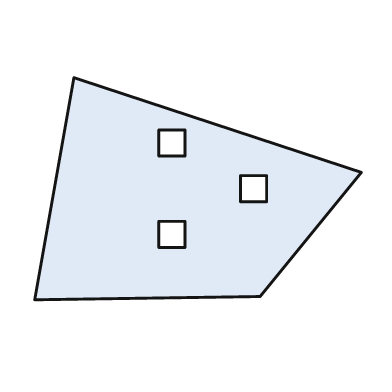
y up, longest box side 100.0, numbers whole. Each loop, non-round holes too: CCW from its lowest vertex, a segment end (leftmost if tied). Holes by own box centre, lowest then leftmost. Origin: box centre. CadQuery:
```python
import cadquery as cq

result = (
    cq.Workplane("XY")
    .moveTo(-50.0, -34.0)
    .lineTo(19.0, -33.0)
    .lineTo(50.0, 5.0)
    .lineTo(-38.0, 34.0)
    .close()
    .moveTo(-12.0, -18.0)
    .lineTo(-4.0, -18.0)
    .lineTo(-4.0, -10.0)
    .lineTo(-12.0, -10.0)
    .close()
    .moveTo(13.0, -4.0)
    .lineTo(21.0, -4.0)
    .lineTo(21.0, 4.0)
    .lineTo(13.0, 4.0)
    .close()
    .moveTo(-12.0, 10.0)
    .lineTo(-4.0, 10.0)
    .lineTo(-4.0, 18.0)
    .lineTo(-12.0, 18.0)
    .close()
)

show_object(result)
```